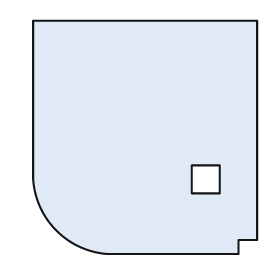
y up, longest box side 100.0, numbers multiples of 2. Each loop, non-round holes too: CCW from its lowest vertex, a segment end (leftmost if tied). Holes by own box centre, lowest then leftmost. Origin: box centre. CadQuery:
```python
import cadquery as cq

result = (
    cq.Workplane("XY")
    .moveTo(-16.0, -50.0)
    .lineTo(40.0, -50.0)
    .lineTo(40.0, -44.0)
    .lineTo(48.0, -44.0)
    .lineTo(48.0, 50.0)
    .lineTo(-48.0, 50.0)
    .lineTo(-48.0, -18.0)
    .threePointArc((-38.0, -40.0), (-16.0, -50.0))
    .close()
    .moveTo(20.0, -24.0)
    .lineTo(32.0, -24.0)
    .lineTo(32.0, -12.0)
    .lineTo(20.0, -12.0)
    .close()
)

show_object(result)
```